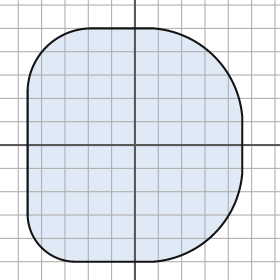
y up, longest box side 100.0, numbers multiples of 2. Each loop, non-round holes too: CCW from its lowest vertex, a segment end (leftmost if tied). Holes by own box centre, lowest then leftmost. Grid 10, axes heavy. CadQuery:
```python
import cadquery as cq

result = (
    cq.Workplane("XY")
    .moveTo(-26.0, -50.0)
    .lineTo(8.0, -50.0)
    .threePointArc((34.0, -38.0), (46.0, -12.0))
    .lineTo(46.0, 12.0)
    .threePointArc((34.0, 38.0), (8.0, 50.0))
    .lineTo(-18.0, 50.0)
    .threePointArc((-38.0, 42.0), (-46.0, 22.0))
    .lineTo(-46.0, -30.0)
    .threePointArc((-40.0, -44.0), (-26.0, -50.0))
    .close()
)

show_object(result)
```